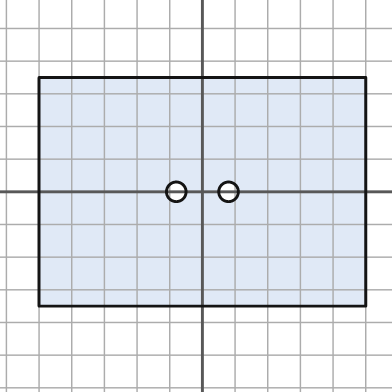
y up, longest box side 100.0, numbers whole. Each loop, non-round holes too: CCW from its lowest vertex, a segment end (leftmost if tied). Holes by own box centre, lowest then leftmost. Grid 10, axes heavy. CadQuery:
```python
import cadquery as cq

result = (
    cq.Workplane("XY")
    .moveTo(-50.0, -35.0)
    .lineTo(50.0, -35.0)
    .lineTo(50.0, 35.0)
    .lineTo(-50.0, 35.0)
    .close()
    .moveTo(-8.0, 0.0)
    .circle(3.0)
    .moveTo(8.0, 0.0)
    .circle(3.0)
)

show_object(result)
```